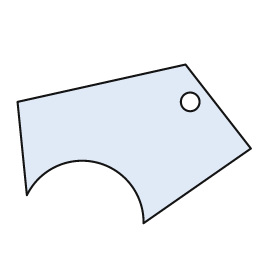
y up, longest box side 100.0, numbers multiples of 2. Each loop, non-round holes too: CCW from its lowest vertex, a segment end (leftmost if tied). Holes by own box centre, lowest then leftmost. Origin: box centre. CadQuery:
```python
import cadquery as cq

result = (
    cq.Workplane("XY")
    .moveTo(4.0, -34.0)
    .lineTo(50.0, -2.0)
    .lineTo(22.0, 34.0)
    .lineTo(-50.0, 18.0)
    .lineTo(-46.0, -22.0)
    .threePointArc((-16.0, -8.0), (4.0, -34.0))
    .close()
    .moveTo(24.0, 18.0)
    .circle(4.0)
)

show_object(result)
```